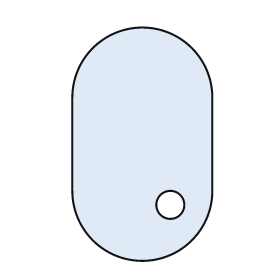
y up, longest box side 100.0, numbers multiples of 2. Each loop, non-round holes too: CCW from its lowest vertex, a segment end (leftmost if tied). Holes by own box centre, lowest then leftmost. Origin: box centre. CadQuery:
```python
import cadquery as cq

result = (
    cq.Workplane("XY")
    .moveTo(-30.0, -20.0)
    .threePointArc((0.0, -50.0), (30.0, -20.0))
    .lineTo(30.0, 20.0)
    .threePointArc((0.0, 50.0), (-30.0, 20.0))
    .close()
    .moveTo(12.0, -26.0)
    .circle(6.0)
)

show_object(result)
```